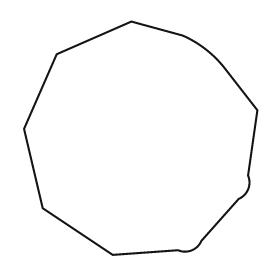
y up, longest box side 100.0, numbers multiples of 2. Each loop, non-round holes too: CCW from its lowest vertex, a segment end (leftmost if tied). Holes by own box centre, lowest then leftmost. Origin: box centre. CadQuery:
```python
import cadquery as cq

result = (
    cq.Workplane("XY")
    .moveTo(-12.0, -50.0)
    .lineTo(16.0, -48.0)
    .threePointArc((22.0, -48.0), (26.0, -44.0))
    .lineTo(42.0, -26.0)
    .threePointArc((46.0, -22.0), (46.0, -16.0))
    .lineTo(50.0, 12.0)
    .lineTo(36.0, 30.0)
    .threePointArc((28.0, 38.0), (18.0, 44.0))
    .lineTo(-4.0, 50.0)
    .lineTo(-36.0, 36.0)
    .lineTo(-50.0, 4.0)
    .lineTo(-42.0, -30.0)
    .close()
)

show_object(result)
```